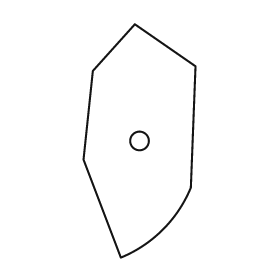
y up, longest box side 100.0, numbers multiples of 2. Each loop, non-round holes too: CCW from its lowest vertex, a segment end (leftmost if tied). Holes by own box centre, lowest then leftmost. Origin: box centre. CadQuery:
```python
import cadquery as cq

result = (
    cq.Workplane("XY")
    .moveTo(-8.0, -50.0)
    .threePointArc((10.0, -38.0), (22.0, -20.0))
    .lineTo(24.0, 32.0)
    .lineTo(-2.0, 50.0)
    .lineTo(-20.0, 30.0)
    .lineTo(-24.0, -8.0)
    .close()
    .moveTo(0.0, 0.0)
    .circle(4.0)
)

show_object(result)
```